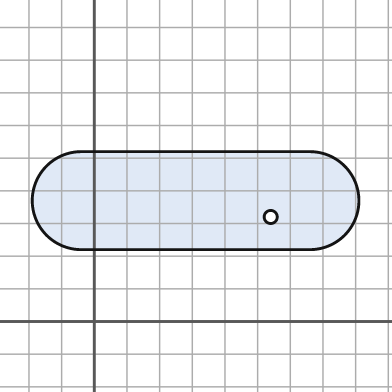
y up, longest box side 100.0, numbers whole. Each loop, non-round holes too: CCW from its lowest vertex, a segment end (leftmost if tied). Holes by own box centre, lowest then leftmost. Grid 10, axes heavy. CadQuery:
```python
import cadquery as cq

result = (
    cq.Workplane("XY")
    .moveTo(-4.0, 22.0)
    .lineTo(66.0, 22.0)
    .threePointArc((81.0, 37.0), (66.0, 52.0))
    .lineTo(-4.0, 52.0)
    .threePointArc((-19.0, 37.0), (-4.0, 22.0))
    .close()
    .moveTo(54.0, 32.0)
    .circle(2.0)
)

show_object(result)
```